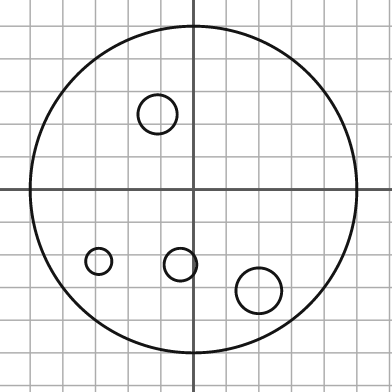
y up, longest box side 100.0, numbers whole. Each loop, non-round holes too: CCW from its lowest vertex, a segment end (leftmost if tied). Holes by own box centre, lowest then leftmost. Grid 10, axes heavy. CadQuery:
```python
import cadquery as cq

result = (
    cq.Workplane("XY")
    .moveTo(0.0, 0.0)
    .circle(50.0)
    .moveTo(20.0, -31.0)
    .circle(7.0)
    .moveTo(-4.0, -23.0)
    .circle(5.0)
    .moveTo(-29.0, -22.0)
    .circle(4.0)
    .moveTo(-11.0, 23.0)
    .circle(6.0)
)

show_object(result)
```